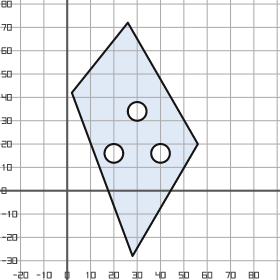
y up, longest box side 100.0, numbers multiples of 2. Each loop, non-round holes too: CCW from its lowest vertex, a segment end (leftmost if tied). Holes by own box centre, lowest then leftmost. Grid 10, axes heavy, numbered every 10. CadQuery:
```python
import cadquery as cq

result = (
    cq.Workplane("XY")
    .moveTo(28.0, -28.0)
    .lineTo(56.0, 20.0)
    .lineTo(26.0, 72.0)
    .lineTo(2.0, 42.0)
    .close()
    .moveTo(20.0, 16.0)
    .circle(4.0)
    .moveTo(40.0, 16.0)
    .circle(4.0)
    .moveTo(30.0, 34.0)
    .circle(4.0)
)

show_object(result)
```